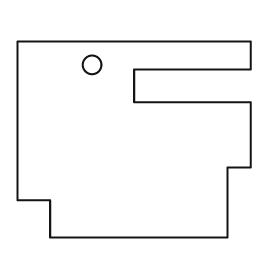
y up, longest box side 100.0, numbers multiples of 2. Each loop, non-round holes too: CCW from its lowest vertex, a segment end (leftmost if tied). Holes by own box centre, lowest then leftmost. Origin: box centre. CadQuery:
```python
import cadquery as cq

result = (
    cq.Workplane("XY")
    .moveTo(-36.0, -42.0)
    .lineTo(40.0, -42.0)
    .lineTo(40.0, -12.0)
    .lineTo(50.0, -12.0)
    .lineTo(50.0, 16.0)
    .lineTo(0.0, 16.0)
    .lineTo(0.0, 30.0)
    .lineTo(50.0, 30.0)
    .lineTo(50.0, 42.0)
    .lineTo(-50.0, 42.0)
    .lineTo(-50.0, -26.0)
    .lineTo(-36.0, -26.0)
    .close()
    .moveTo(-18.0, 32.0)
    .circle(4.0)
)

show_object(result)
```